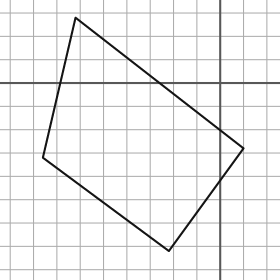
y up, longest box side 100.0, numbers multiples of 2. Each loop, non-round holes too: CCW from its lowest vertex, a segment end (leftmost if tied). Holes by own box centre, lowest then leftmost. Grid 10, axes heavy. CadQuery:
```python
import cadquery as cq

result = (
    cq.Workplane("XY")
    .moveTo(-22.0, -72.0)
    .lineTo(10.0, -28.0)
    .lineTo(-62.0, 28.0)
    .lineTo(-76.0, -32.0)
    .close()
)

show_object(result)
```